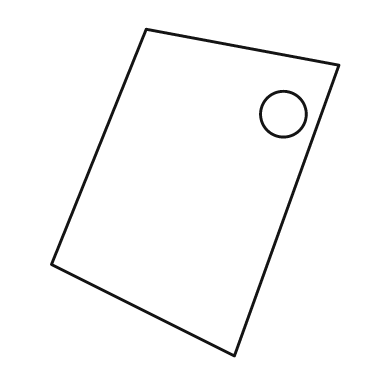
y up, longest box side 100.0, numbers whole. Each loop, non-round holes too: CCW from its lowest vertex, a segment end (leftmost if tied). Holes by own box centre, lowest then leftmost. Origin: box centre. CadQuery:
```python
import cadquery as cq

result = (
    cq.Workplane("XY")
    .moveTo(12.0, -50.0)
    .lineTo(44.0, 39.0)
    .lineTo(-15.0, 50.0)
    .lineTo(-44.0, -22.0)
    .close()
    .moveTo(27.0, 24.0)
    .circle(7.0)
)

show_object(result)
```